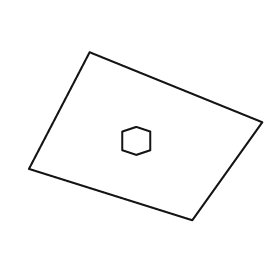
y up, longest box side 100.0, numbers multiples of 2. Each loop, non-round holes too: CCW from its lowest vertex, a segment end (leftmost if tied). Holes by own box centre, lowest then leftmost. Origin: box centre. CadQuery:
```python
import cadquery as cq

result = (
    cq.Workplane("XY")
    .moveTo(20.0, -36.0)
    .lineTo(50.0, 6.0)
    .lineTo(-24.0, 36.0)
    .lineTo(-50.0, -14.0)
    .close()
    .moveTo(-4.0, -8.0)
    .lineTo(2.0, -6.0)
    .lineTo(2.0, 2.0)
    .lineTo(-4.0, 4.0)
    .lineTo(-10.0, 2.0)
    .lineTo(-10.0, -6.0)
    .close()
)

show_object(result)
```